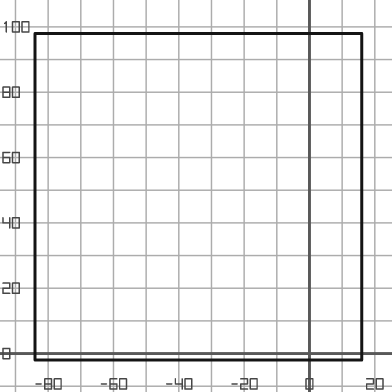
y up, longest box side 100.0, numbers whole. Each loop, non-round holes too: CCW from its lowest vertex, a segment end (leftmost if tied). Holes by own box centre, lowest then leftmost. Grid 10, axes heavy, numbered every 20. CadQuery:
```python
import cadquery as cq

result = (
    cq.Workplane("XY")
    .moveTo(-84.0, -2.0)
    .lineTo(16.0, -2.0)
    .lineTo(16.0, 98.0)
    .lineTo(-84.0, 98.0)
    .close()
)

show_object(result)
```